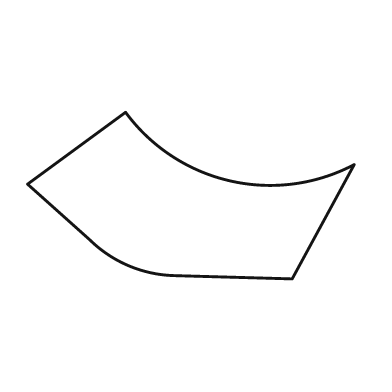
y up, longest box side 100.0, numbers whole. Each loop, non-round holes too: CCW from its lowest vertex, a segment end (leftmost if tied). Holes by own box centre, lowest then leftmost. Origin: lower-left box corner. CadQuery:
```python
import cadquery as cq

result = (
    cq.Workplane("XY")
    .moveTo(81.0, 0.0)
    .lineTo(100.0, 35.0)
    .threePointArc((62.0, 30.0), (30.0, 51.0))
    .lineTo(0.0, 29.0)
    .lineTo(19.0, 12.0)
    .threePointArc((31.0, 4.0), (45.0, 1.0))
    .close()
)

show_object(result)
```